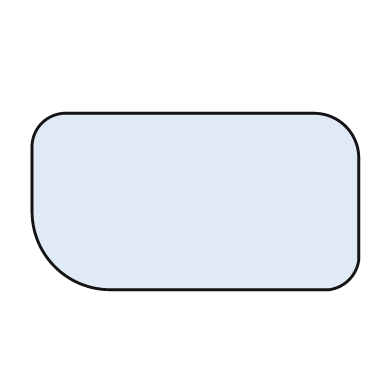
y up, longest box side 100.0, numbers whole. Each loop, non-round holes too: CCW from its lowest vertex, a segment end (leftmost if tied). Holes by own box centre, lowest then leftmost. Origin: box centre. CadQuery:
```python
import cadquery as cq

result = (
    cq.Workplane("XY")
    .moveTo(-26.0, -27.0)
    .lineTo(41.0, -27.0)
    .threePointArc((47.0, -24.0), (50.0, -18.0))
    .lineTo(50.0, 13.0)
    .threePointArc((46.0, 23.0), (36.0, 27.0))
    .lineTo(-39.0, 27.0)
    .threePointArc((-47.0, 24.0), (-50.0, 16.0))
    .lineTo(-50.0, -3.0)
    .threePointArc((-43.0, -20.0), (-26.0, -27.0))
    .close()
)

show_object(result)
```